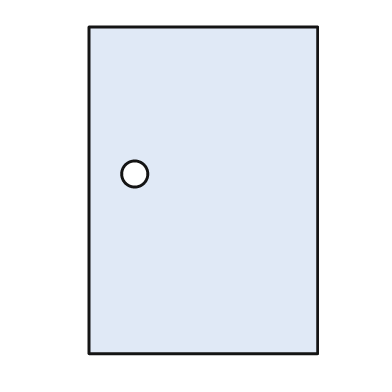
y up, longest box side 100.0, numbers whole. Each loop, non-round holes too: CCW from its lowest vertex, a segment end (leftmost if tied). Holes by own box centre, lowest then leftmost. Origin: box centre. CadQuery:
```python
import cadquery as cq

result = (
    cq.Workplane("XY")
    .moveTo(-35.0, -50.0)
    .lineTo(35.0, -50.0)
    .lineTo(35.0, 50.0)
    .lineTo(-35.0, 50.0)
    .close()
    .moveTo(-21.0, 5.0)
    .circle(4.0)
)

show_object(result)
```